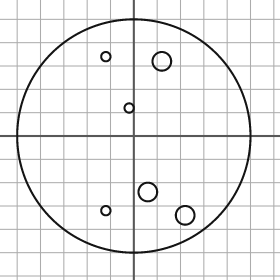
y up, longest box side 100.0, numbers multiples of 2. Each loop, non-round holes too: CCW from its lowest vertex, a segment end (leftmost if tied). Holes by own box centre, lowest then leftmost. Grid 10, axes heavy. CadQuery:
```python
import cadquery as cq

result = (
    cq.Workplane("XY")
    .moveTo(0.0, 0.0)
    .circle(50.0)
    .moveTo(22.0, -34.0)
    .circle(4.0)
    .moveTo(-12.0, -32.0)
    .circle(2.0)
    .moveTo(6.0, -24.0)
    .circle(4.0)
    .moveTo(-2.0, 12.0)
    .circle(2.0)
    .moveTo(12.0, 32.0)
    .circle(4.0)
    .moveTo(-12.0, 34.0)
    .circle(2.0)
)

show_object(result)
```